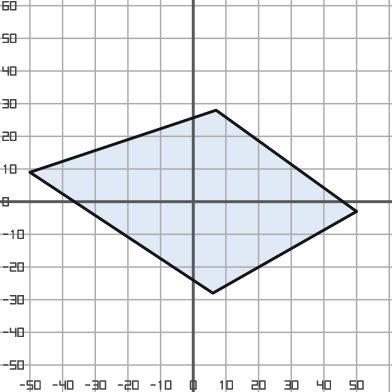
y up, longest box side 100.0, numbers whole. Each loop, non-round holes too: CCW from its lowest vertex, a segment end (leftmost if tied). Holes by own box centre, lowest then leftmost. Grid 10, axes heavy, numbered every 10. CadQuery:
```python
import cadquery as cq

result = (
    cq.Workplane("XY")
    .moveTo(6.0, -28.0)
    .lineTo(50.0, -3.0)
    .lineTo(7.0, 28.0)
    .lineTo(-50.0, 9.0)
    .close()
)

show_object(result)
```